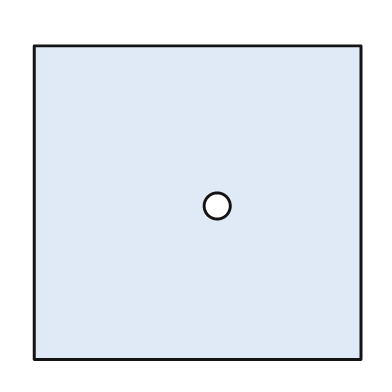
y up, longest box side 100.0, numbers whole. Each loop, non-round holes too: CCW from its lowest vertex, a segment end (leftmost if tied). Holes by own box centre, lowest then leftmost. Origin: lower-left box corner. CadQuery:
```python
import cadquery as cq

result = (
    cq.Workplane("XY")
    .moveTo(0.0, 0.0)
    .lineTo(100.0, 0.0)
    .lineTo(100.0, 96.0)
    .lineTo(0.0, 96.0)
    .close()
    .moveTo(56.0, 47.0)
    .circle(4.0)
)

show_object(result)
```